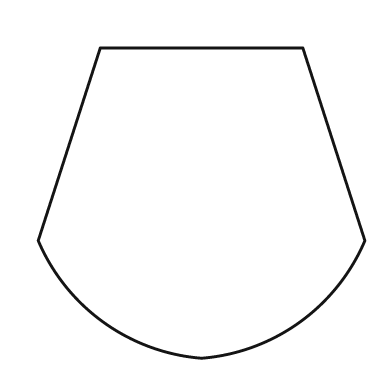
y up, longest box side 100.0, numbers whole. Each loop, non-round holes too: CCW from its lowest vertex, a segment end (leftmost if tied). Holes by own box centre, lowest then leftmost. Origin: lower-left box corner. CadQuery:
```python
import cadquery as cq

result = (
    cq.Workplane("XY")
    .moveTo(50.0, 0.0)
    .threePointArc((80.0, 11.0), (100.0, 36.0))
    .lineTo(81.0, 95.0)
    .lineTo(19.0, 95.0)
    .lineTo(0.0, 36.0)
    .threePointArc((20.0, 11.0), (50.0, 0.0))
    .close()
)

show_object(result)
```